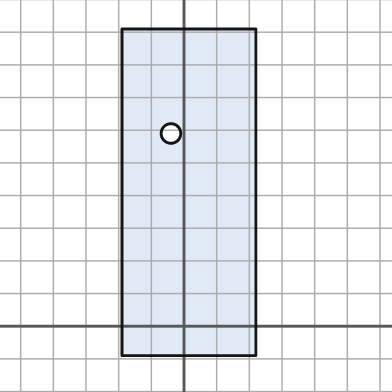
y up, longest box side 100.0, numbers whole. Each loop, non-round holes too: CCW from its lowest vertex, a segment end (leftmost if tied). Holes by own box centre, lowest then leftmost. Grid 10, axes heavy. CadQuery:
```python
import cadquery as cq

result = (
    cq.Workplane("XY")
    .moveTo(-19.0, -9.0)
    .lineTo(22.0, -9.0)
    .lineTo(22.0, 91.0)
    .lineTo(-19.0, 91.0)
    .close()
    .moveTo(-4.0, 59.0)
    .circle(3.0)
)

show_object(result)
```